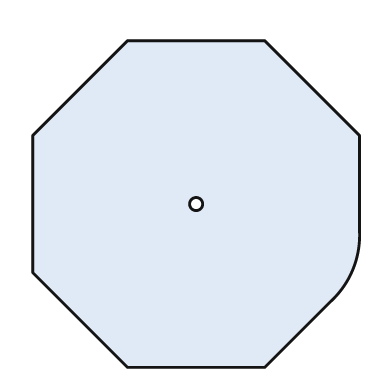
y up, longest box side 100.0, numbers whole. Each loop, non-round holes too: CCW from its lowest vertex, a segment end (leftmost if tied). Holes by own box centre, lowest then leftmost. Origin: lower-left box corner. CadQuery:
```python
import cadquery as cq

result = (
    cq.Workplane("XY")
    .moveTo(29.0, 0.0)
    .lineTo(71.0, 0.0)
    .lineTo(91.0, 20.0)
    .threePointArc((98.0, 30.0), (100.0, 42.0))
    .lineTo(100.0, 71.0)
    .lineTo(71.0, 100.0)
    .lineTo(29.0, 100.0)
    .lineTo(0.0, 71.0)
    .lineTo(0.0, 29.0)
    .close()
    .moveTo(50.0, 50.0)
    .circle(2.0)
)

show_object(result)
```